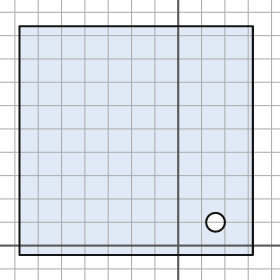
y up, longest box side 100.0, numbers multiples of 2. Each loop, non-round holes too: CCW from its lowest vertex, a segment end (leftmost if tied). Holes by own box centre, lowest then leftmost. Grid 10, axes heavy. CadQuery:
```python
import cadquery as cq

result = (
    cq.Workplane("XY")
    .moveTo(-68.0, -4.0)
    .lineTo(32.0, -4.0)
    .lineTo(32.0, 94.0)
    .lineTo(-68.0, 94.0)
    .close()
    .moveTo(16.0, 10.0)
    .circle(4.0)
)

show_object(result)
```